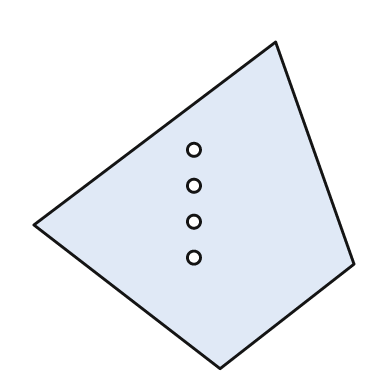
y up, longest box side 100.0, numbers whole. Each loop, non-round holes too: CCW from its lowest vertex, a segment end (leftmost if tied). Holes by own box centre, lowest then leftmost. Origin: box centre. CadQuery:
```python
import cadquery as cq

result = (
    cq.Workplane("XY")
    .moveTo(8.0, -50.0)
    .lineTo(49.0, -18.0)
    .lineTo(25.0, 50.0)
    .lineTo(-49.0, -6.0)
    .close()
    .moveTo(0.0, -16.0)
    .circle(2.0)
    .moveTo(0.0, -5.0)
    .circle(2.0)
    .moveTo(0.0, 6.0)
    .circle(2.0)
    .moveTo(0.0, 17.0)
    .circle(2.0)
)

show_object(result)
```